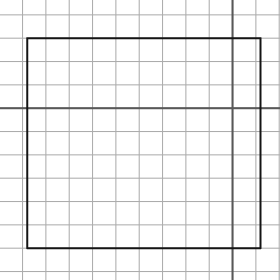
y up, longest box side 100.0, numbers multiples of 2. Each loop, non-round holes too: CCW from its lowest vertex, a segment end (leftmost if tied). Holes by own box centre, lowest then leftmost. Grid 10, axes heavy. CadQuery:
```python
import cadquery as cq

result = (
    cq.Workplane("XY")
    .moveTo(-88.0, -60.0)
    .lineTo(12.0, -60.0)
    .lineTo(12.0, 30.0)
    .lineTo(-88.0, 30.0)
    .close()
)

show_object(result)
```